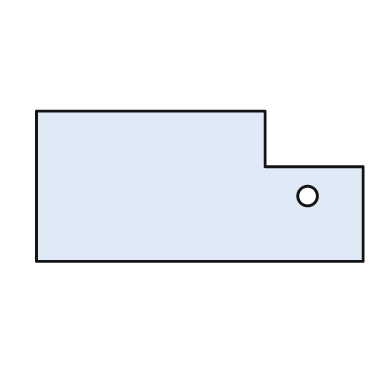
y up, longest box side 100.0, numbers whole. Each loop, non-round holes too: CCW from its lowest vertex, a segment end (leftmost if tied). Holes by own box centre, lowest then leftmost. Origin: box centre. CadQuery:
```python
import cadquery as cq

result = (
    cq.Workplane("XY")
    .moveTo(-50.0, -23.0)
    .lineTo(50.0, -23.0)
    .lineTo(50.0, 6.0)
    .lineTo(20.0, 6.0)
    .lineTo(20.0, 23.0)
    .lineTo(-50.0, 23.0)
    .close()
    .moveTo(33.0, -3.0)
    .circle(3.0)
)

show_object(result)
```